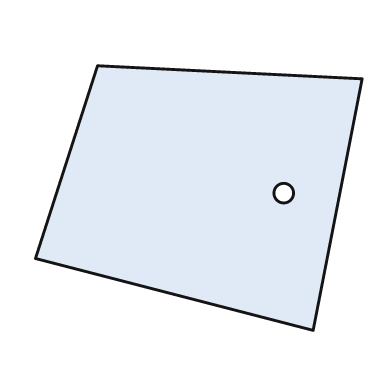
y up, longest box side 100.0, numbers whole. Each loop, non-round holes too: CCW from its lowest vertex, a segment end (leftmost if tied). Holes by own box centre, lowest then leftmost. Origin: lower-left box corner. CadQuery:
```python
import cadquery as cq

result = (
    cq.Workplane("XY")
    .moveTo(85.0, 0.0)
    .lineTo(100.0, 77.0)
    .lineTo(19.0, 81.0)
    .lineTo(0.0, 22.0)
    .close()
    .moveTo(76.0, 42.0)
    .circle(3.0)
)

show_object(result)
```